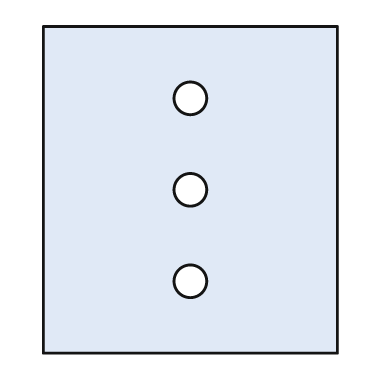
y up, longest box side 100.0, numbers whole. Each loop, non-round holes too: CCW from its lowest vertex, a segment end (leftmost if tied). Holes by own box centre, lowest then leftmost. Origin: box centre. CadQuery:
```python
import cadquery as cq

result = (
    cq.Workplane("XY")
    .moveTo(-45.0, -50.0)
    .lineTo(45.0, -50.0)
    .lineTo(45.0, 50.0)
    .lineTo(-45.0, 50.0)
    .close()
    .moveTo(0.0, -28.0)
    .circle(5.0)
    .moveTo(0.0, 0.0)
    .circle(5.0)
    .moveTo(0.0, 28.0)
    .circle(5.0)
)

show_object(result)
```